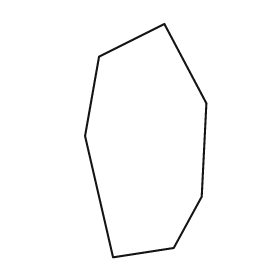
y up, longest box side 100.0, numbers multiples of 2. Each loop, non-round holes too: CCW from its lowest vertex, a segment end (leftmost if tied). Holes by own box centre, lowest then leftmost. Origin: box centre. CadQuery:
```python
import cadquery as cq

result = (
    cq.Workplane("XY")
    .moveTo(-14.0, -50.0)
    .lineTo(12.0, -46.0)
    .lineTo(24.0, -24.0)
    .lineTo(26.0, 16.0)
    .lineTo(8.0, 50.0)
    .lineTo(-20.0, 36.0)
    .lineTo(-26.0, 2.0)
    .close()
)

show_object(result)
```